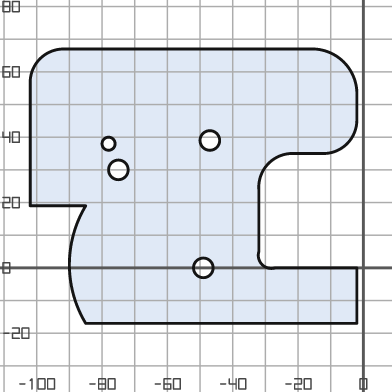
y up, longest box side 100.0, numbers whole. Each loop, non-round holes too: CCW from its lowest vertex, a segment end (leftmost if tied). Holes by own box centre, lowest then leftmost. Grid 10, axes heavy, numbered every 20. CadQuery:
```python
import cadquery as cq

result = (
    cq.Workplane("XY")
    .moveTo(-85.0, -17.0)
    .lineTo(-2.0, -17.0)
    .lineTo(-2.0, 0.0)
    .lineTo(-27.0, 0.0)
    .threePointArc((-31.0, 1.0), (-32.0, 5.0))
    .lineTo(-32.0, 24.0)
    .threePointArc((-29.0, 32.0), (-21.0, 35.0))
    .lineTo(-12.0, 35.0)
    .threePointArc((-5.0, 38.0), (-2.0, 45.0))
    .lineTo(-2.0, 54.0)
    .threePointArc((-6.0, 63.0), (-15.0, 67.0))
    .lineTo(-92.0, 67.0)
    .threePointArc((-99.0, 64.0), (-102.0, 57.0))
    .lineTo(-102.0, 19.0)
    .lineTo(-85.0, 19.0)
    .threePointArc((-90.0, 1.0), (-85.0, -17.0))
    .close()
    .moveTo(-49.0, 0.0)
    .circle(3.0)
    .moveTo(-75.0, 30.0)
    .circle(3.0)
    .moveTo(-78.0, 38.0)
    .circle(2.0)
    .moveTo(-47.0, 39.0)
    .circle(3.0)
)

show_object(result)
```